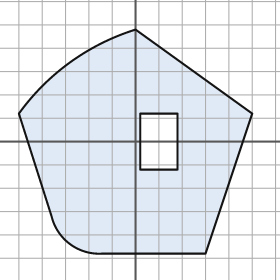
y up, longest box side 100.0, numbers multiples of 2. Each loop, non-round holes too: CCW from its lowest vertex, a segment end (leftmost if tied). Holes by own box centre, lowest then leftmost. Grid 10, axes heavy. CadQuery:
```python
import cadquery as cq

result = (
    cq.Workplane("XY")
    .moveTo(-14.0, -48.0)
    .lineTo(30.0, -48.0)
    .lineTo(50.0, 12.0)
    .lineTo(0.0, 48.0)
    .threePointArc((-28.0, 34.0), (-50.0, 12.0))
    .lineTo(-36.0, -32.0)
    .threePointArc((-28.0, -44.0), (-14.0, -48.0))
    .close()
    .moveTo(2.0, -12.0)
    .lineTo(18.0, -12.0)
    .lineTo(18.0, 12.0)
    .lineTo(2.0, 12.0)
    .close()
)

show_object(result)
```